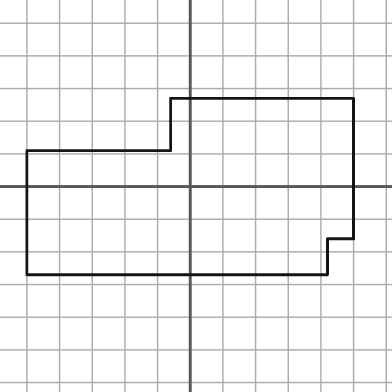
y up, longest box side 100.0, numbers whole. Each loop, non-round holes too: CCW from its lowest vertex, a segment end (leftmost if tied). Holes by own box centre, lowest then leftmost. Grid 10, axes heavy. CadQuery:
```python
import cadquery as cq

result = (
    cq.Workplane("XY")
    .moveTo(-50.0, -27.0)
    .lineTo(42.0, -27.0)
    .lineTo(42.0, -16.0)
    .lineTo(50.0, -16.0)
    .lineTo(50.0, 27.0)
    .lineTo(-6.0, 27.0)
    .lineTo(-6.0, 11.0)
    .lineTo(-50.0, 11.0)
    .close()
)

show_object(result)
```